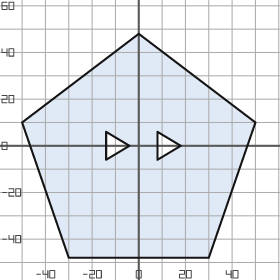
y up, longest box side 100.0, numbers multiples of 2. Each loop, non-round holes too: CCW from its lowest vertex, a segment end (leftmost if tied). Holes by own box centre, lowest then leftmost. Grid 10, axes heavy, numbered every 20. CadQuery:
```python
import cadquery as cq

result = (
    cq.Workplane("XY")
    .moveTo(-30.0, -48.0)
    .lineTo(30.0, -48.0)
    .lineTo(50.0, 10.0)
    .lineTo(0.0, 48.0)
    .lineTo(-50.0, 10.0)
    .close()
    .moveTo(-14.0, -6.0)
    .lineTo(-4.0, 0.0)
    .lineTo(-14.0, 6.0)
    .close()
    .moveTo(8.0, -6.0)
    .lineTo(18.0, 0.0)
    .lineTo(8.0, 6.0)
    .close()
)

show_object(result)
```